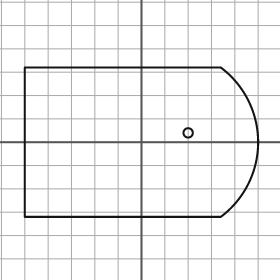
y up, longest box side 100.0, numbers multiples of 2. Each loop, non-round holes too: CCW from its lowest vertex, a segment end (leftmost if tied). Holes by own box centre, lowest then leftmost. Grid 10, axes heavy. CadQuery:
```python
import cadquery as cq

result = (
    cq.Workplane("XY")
    .moveTo(-50.0, -32.0)
    .lineTo(34.0, -32.0)
    .threePointArc((50.0, 0.0), (34.0, 32.0))
    .lineTo(-50.0, 32.0)
    .close()
    .moveTo(20.0, 4.0)
    .circle(2.0)
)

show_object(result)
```